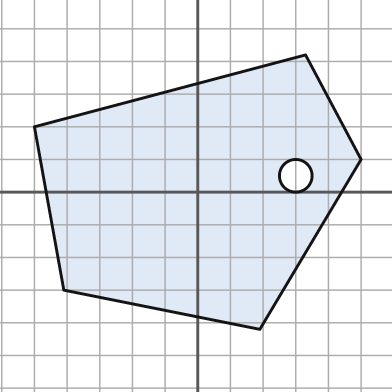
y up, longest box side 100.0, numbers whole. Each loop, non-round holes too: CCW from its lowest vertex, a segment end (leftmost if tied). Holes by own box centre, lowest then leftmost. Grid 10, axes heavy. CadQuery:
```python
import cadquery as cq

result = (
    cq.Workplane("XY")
    .moveTo(19.0, -42.0)
    .lineTo(50.0, 10.0)
    .lineTo(33.0, 42.0)
    .lineTo(-50.0, 20.0)
    .lineTo(-41.0, -30.0)
    .close()
    .moveTo(30.0, 5.0)
    .circle(5.0)
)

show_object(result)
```